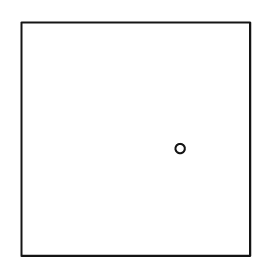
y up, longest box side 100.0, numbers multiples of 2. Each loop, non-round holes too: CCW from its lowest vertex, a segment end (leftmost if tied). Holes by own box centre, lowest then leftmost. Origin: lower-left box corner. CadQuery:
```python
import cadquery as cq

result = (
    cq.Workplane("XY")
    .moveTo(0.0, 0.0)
    .lineTo(98.0, 0.0)
    .lineTo(98.0, 100.0)
    .lineTo(0.0, 100.0)
    .close()
    .moveTo(68.0, 46.0)
    .circle(2.0)
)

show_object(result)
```